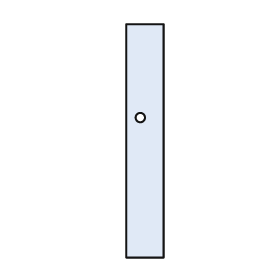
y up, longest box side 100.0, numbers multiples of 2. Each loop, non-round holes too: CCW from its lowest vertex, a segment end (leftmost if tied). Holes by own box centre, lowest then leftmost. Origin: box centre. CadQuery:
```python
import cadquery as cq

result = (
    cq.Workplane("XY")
    .moveTo(-8.0, -50.0)
    .lineTo(8.0, -50.0)
    .lineTo(8.0, 50.0)
    .lineTo(-8.0, 50.0)
    .close()
    .moveTo(-2.0, 10.0)
    .circle(2.0)
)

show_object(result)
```